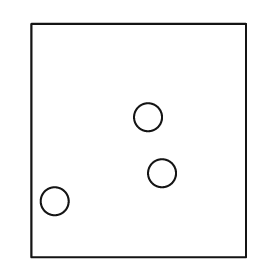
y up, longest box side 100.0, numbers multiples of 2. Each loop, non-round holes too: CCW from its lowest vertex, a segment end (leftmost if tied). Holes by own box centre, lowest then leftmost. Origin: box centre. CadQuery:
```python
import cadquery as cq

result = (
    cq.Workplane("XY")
    .moveTo(-46.0, -50.0)
    .lineTo(46.0, -50.0)
    .lineTo(46.0, 50.0)
    .lineTo(-46.0, 50.0)
    .close()
    .moveTo(-36.0, -26.0)
    .circle(6.0)
    .moveTo(10.0, -14.0)
    .circle(6.0)
    .moveTo(4.0, 10.0)
    .circle(6.0)
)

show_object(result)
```